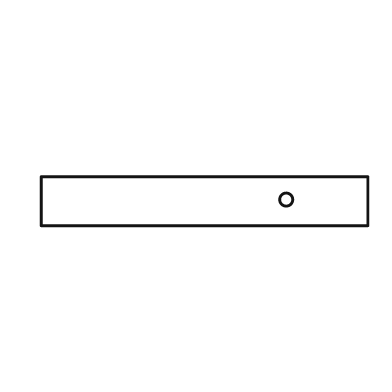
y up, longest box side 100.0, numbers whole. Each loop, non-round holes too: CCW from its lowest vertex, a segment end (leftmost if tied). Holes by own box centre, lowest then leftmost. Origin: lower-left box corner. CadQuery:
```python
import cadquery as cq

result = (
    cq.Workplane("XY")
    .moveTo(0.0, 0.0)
    .lineTo(100.0, 0.0)
    .lineTo(100.0, 15.0)
    .lineTo(0.0, 15.0)
    .close()
    .moveTo(75.0, 8.0)
    .circle(2.0)
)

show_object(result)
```